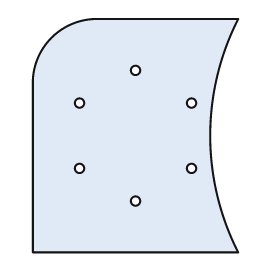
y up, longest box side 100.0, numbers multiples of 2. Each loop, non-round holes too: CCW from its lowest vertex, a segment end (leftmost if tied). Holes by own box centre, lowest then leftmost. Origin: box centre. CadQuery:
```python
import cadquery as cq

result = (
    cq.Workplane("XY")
    .moveTo(-44.0, -50.0)
    .lineTo(44.0, -50.0)
    .threePointArc((32.0, 0.0), (44.0, 50.0))
    .lineTo(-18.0, 50.0)
    .threePointArc((-36.0, 42.0), (-44.0, 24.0))
    .close()
    .moveTo(0.0, -28.0)
    .circle(2.0)
    .moveTo(-24.0, -14.0)
    .circle(2.0)
    .moveTo(24.0, -14.0)
    .circle(2.0)
    .moveTo(-24.0, 14.0)
    .circle(2.0)
    .moveTo(24.0, 14.0)
    .circle(2.0)
    .moveTo(0.0, 28.0)
    .circle(2.0)
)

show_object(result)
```